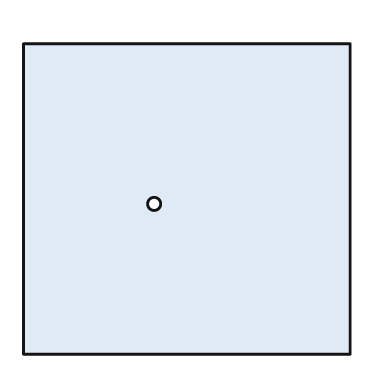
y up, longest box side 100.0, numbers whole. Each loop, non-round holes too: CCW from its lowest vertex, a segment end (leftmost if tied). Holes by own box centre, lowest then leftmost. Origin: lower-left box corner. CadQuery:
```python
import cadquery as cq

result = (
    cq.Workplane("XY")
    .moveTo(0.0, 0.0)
    .lineTo(100.0, 0.0)
    .lineTo(100.0, 95.0)
    .lineTo(0.0, 95.0)
    .close()
    .moveTo(40.0, 46.0)
    .circle(2.0)
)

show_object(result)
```